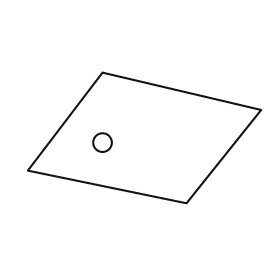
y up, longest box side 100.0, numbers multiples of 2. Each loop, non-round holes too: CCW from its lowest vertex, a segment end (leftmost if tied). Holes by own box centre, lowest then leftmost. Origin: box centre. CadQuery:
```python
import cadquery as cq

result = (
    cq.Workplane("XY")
    .moveTo(18.0, -28.0)
    .lineTo(50.0, 12.0)
    .lineTo(-18.0, 28.0)
    .lineTo(-50.0, -14.0)
    .close()
    .moveTo(-18.0, -2.0)
    .circle(4.0)
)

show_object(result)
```